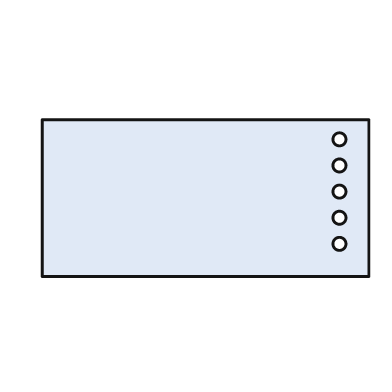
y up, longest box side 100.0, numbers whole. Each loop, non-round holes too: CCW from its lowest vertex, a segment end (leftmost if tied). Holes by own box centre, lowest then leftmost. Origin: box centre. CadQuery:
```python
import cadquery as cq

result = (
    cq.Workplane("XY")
    .moveTo(-50.0, -24.0)
    .lineTo(50.0, -24.0)
    .lineTo(50.0, 24.0)
    .lineTo(-50.0, 24.0)
    .close()
    .moveTo(41.0, -14.0)
    .circle(2.0)
    .moveTo(41.0, -6.0)
    .circle(2.0)
    .moveTo(41.0, 2.0)
    .circle(2.0)
    .moveTo(41.0, 10.0)
    .circle(2.0)
    .moveTo(41.0, 18.0)
    .circle(2.0)
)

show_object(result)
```